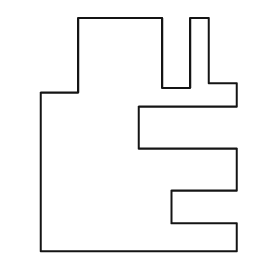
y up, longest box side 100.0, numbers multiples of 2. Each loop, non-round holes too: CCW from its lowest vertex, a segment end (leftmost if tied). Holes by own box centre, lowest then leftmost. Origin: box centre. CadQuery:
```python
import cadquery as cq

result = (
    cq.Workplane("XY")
    .moveTo(-42.0, -50.0)
    .lineTo(42.0, -50.0)
    .lineTo(42.0, -38.0)
    .lineTo(14.0, -38.0)
    .lineTo(14.0, -24.0)
    .lineTo(42.0, -24.0)
    .lineTo(42.0, -6.0)
    .lineTo(0.0, -6.0)
    .lineTo(0.0, 12.0)
    .lineTo(42.0, 12.0)
    .lineTo(42.0, 22.0)
    .lineTo(30.0, 22.0)
    .lineTo(30.0, 50.0)
    .lineTo(22.0, 50.0)
    .lineTo(22.0, 20.0)
    .lineTo(10.0, 20.0)
    .lineTo(10.0, 50.0)
    .lineTo(-26.0, 50.0)
    .lineTo(-26.0, 18.0)
    .lineTo(-42.0, 18.0)
    .close()
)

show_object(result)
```